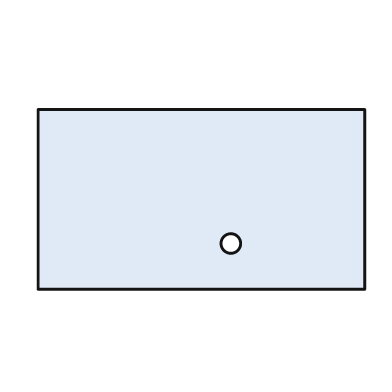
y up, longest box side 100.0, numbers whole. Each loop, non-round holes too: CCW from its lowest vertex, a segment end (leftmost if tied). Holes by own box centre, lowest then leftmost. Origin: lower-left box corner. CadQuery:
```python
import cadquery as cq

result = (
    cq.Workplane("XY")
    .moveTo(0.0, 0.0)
    .lineTo(100.0, 0.0)
    .lineTo(100.0, 55.0)
    .lineTo(0.0, 55.0)
    .close()
    .moveTo(59.0, 14.0)
    .circle(3.0)
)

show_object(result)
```